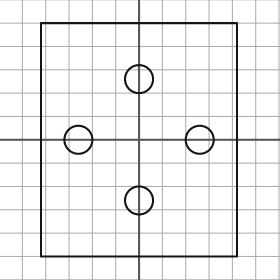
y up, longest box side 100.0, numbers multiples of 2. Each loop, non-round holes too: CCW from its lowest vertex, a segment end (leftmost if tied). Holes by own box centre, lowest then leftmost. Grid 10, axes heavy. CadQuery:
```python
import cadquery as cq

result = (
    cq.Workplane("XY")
    .moveTo(-42.0, -50.0)
    .lineTo(42.0, -50.0)
    .lineTo(42.0, 50.0)
    .lineTo(-42.0, 50.0)
    .close()
    .moveTo(0.0, -26.0)
    .circle(6.0)
    .moveTo(-26.0, 0.0)
    .circle(6.0)
    .moveTo(26.0, 0.0)
    .circle(6.0)
    .moveTo(0.0, 26.0)
    .circle(6.0)
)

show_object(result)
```